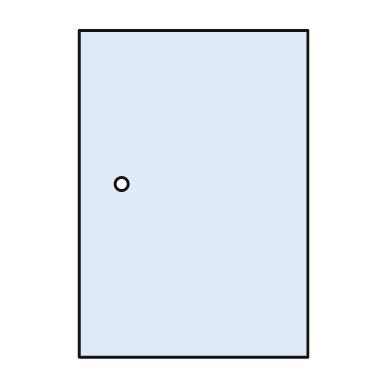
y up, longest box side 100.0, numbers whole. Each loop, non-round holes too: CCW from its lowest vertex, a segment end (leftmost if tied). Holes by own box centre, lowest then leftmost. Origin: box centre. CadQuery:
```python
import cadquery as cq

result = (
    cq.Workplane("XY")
    .moveTo(-35.0, -50.0)
    .lineTo(35.0, -50.0)
    .lineTo(35.0, 50.0)
    .lineTo(-35.0, 50.0)
    .close()
    .moveTo(-22.0, 3.0)
    .circle(2.0)
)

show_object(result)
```